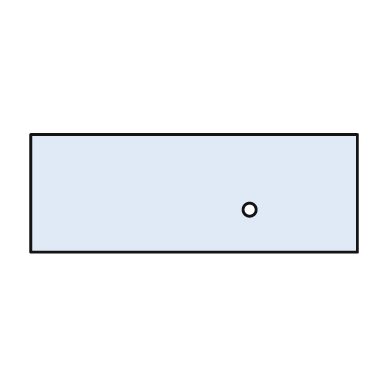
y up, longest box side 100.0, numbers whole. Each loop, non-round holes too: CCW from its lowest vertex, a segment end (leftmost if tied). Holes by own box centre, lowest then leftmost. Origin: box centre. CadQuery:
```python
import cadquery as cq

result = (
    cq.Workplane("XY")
    .moveTo(-50.0, -18.0)
    .lineTo(50.0, -18.0)
    .lineTo(50.0, 18.0)
    .lineTo(-50.0, 18.0)
    .close()
    .moveTo(17.0, -5.0)
    .circle(2.0)
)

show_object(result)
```